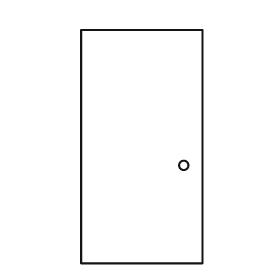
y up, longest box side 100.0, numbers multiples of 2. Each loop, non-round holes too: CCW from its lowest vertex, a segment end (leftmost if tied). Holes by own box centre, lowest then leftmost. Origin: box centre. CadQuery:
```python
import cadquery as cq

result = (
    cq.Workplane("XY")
    .moveTo(-26.0, -50.0)
    .lineTo(26.0, -50.0)
    .lineTo(26.0, 50.0)
    .lineTo(-26.0, 50.0)
    .close()
    .moveTo(18.0, -8.0)
    .circle(2.0)
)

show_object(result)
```